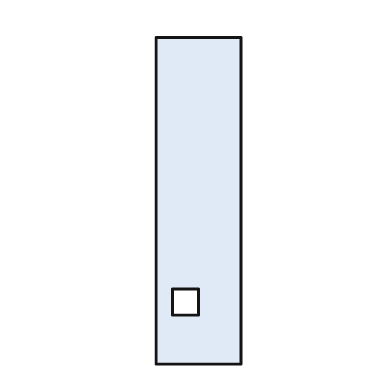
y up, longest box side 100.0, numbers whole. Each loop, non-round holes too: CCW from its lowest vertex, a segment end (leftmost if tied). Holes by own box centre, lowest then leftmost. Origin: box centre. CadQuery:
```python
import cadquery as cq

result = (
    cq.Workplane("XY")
    .moveTo(-13.0, -50.0)
    .lineTo(13.0, -50.0)
    .lineTo(13.0, 50.0)
    .lineTo(-13.0, 50.0)
    .close()
    .moveTo(-8.0, -35.0)
    .lineTo(0.0, -35.0)
    .lineTo(0.0, -27.0)
    .lineTo(-8.0, -27.0)
    .close()
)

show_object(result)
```